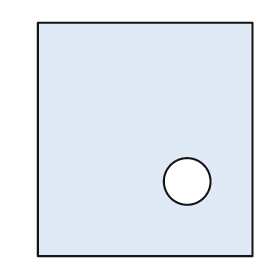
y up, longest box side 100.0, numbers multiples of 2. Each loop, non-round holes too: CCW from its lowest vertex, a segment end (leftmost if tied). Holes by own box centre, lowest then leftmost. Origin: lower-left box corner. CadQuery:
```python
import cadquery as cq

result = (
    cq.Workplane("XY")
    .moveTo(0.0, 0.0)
    .lineTo(92.0, 0.0)
    .lineTo(92.0, 100.0)
    .lineTo(0.0, 100.0)
    .close()
    .moveTo(64.0, 32.0)
    .circle(10.0)
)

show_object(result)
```